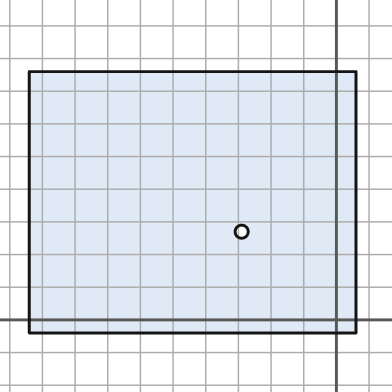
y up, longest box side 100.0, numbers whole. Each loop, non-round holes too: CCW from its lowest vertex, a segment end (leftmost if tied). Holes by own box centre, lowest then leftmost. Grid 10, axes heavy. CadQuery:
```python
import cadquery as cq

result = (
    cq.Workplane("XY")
    .moveTo(-94.0, -4.0)
    .lineTo(6.0, -4.0)
    .lineTo(6.0, 76.0)
    .lineTo(-94.0, 76.0)
    .close()
    .moveTo(-29.0, 27.0)
    .circle(2.0)
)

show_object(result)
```